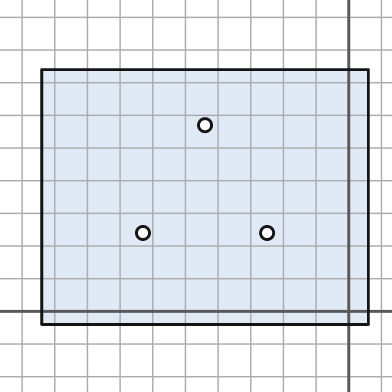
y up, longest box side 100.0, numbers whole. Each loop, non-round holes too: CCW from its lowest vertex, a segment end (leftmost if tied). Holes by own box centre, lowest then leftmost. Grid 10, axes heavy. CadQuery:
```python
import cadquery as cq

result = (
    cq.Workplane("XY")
    .moveTo(-94.0, -4.0)
    .lineTo(6.0, -4.0)
    .lineTo(6.0, 74.0)
    .lineTo(-94.0, 74.0)
    .close()
    .moveTo(-63.0, 24.0)
    .circle(2.0)
    .moveTo(-25.0, 24.0)
    .circle(2.0)
    .moveTo(-44.0, 57.0)
    .circle(2.0)
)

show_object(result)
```